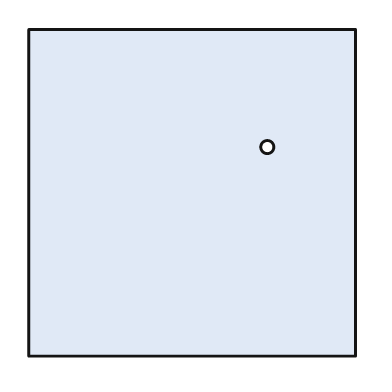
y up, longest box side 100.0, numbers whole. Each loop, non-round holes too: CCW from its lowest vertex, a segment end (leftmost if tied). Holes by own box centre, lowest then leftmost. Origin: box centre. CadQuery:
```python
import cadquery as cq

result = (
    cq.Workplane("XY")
    .moveTo(-50.0, -50.0)
    .lineTo(50.0, -50.0)
    .lineTo(50.0, 50.0)
    .lineTo(-50.0, 50.0)
    .close()
    .moveTo(23.0, 14.0)
    .circle(2.0)
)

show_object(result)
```